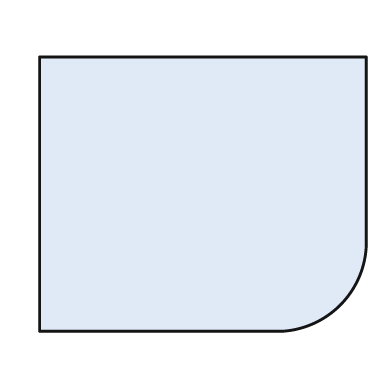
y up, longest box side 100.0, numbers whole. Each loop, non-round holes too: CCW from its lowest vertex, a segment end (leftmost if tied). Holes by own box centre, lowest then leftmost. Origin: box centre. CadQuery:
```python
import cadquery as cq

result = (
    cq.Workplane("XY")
    .moveTo(-50.0, -42.0)
    .lineTo(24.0, -42.0)
    .threePointArc((42.0, -34.0), (50.0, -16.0))
    .lineTo(50.0, 42.0)
    .lineTo(-50.0, 42.0)
    .close()
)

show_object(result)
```